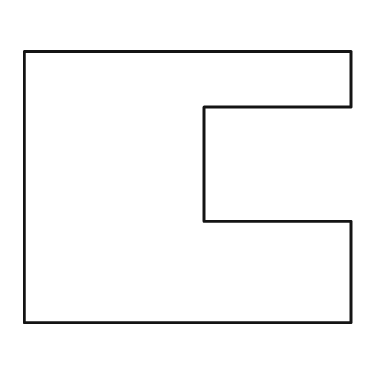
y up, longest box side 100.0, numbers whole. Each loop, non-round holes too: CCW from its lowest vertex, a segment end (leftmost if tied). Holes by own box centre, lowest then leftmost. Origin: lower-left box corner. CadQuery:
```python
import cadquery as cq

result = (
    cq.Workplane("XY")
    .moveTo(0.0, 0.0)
    .lineTo(100.0, 0.0)
    .lineTo(100.0, 31.0)
    .lineTo(55.0, 31.0)
    .lineTo(55.0, 66.0)
    .lineTo(100.0, 66.0)
    .lineTo(100.0, 83.0)
    .lineTo(0.0, 83.0)
    .close()
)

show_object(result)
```